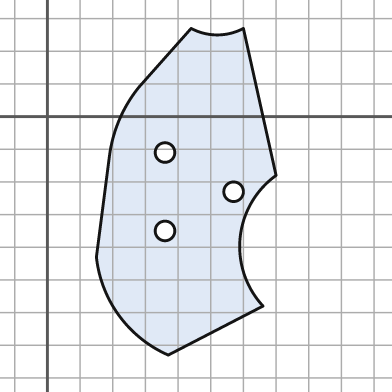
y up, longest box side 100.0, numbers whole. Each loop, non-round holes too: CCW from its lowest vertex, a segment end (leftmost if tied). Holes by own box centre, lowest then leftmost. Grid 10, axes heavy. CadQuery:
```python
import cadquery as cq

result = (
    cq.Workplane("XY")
    .moveTo(37.0, -73.0)
    .lineTo(66.0, -58.0)
    .threePointArc((59.0, -37.0), (70.0, -18.0))
    .lineTo(60.0, 27.0)
    .threePointArc((52.0, 25.0), (44.0, 27.0))
    .lineTo(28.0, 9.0)
    .threePointArc((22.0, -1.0), (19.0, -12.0))
    .lineTo(15.0, -43.0)
    .threePointArc((22.0, -61.0), (37.0, -73.0))
    .close()
    .moveTo(36.0, -35.0)
    .circle(3.0)
    .moveTo(57.0, -23.0)
    .circle(3.0)
    .moveTo(36.0, -11.0)
    .circle(3.0)
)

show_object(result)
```